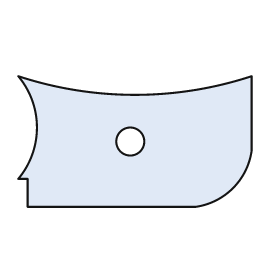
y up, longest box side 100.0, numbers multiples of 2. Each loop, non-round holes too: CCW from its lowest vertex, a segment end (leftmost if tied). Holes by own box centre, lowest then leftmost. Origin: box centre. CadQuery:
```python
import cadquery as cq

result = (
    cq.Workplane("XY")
    .moveTo(-46.0, -28.0)
    .lineTo(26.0, -28.0)
    .threePointArc((42.0, -20.0), (50.0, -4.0))
    .lineTo(50.0, 28.0)
    .threePointArc((0.0, 20.0), (-50.0, 28.0))
    .threePointArc((-42.0, 6.0), (-50.0, -16.0))
    .lineTo(-46.0, -16.0)
    .close()
    .moveTo(-2.0, 0.0)
    .circle(6.0)
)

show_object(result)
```